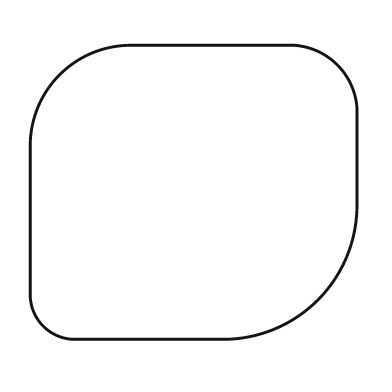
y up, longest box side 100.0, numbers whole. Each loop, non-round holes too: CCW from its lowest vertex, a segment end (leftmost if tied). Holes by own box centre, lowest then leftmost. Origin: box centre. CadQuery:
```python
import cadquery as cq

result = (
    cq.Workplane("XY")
    .moveTo(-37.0, -45.0)
    .lineTo(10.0, -45.0)
    .threePointArc((38.0, -33.0), (50.0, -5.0))
    .lineTo(50.0, 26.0)
    .threePointArc((44.0, 39.0), (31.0, 45.0))
    .lineTo(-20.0, 45.0)
    .threePointArc((-41.0, 36.0), (-50.0, 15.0))
    .lineTo(-50.0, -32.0)
    .threePointArc((-46.0, -41.0), (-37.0, -45.0))
    .close()
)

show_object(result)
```